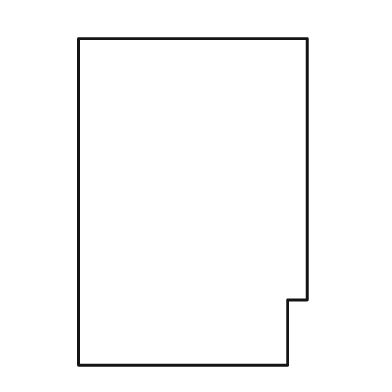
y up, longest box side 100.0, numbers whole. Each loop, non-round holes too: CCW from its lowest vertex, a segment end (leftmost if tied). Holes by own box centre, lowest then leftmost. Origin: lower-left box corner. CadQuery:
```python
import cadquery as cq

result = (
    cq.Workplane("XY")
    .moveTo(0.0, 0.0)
    .lineTo(64.0, 0.0)
    .lineTo(64.0, 20.0)
    .lineTo(70.0, 20.0)
    .lineTo(70.0, 100.0)
    .lineTo(0.0, 100.0)
    .close()
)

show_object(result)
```